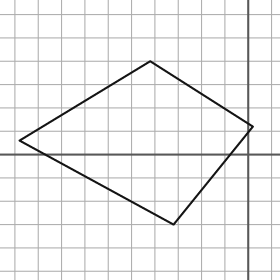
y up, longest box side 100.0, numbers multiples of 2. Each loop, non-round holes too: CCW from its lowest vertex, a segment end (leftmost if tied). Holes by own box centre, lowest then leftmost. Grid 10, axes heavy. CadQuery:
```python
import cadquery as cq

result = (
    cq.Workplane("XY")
    .moveTo(-32.0, -30.0)
    .lineTo(2.0, 12.0)
    .lineTo(-42.0, 40.0)
    .lineTo(-98.0, 6.0)
    .close()
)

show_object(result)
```